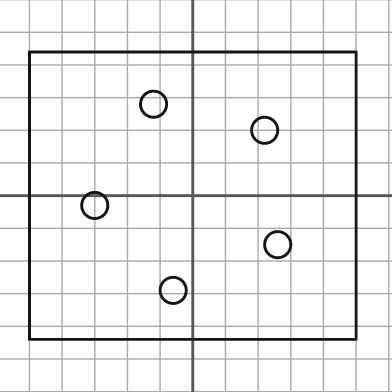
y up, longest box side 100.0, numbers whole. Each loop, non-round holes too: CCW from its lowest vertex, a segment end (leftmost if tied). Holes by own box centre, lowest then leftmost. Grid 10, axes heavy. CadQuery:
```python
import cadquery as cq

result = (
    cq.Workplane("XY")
    .moveTo(-50.0, -44.0)
    .lineTo(50.0, -44.0)
    .lineTo(50.0, 44.0)
    .lineTo(-50.0, 44.0)
    .close()
    .moveTo(-6.0, -29.0)
    .circle(4.0)
    .moveTo(26.0, -15.0)
    .circle(4.0)
    .moveTo(-30.0, -3.0)
    .circle(4.0)
    .moveTo(22.0, 20.0)
    .circle(4.0)
    .moveTo(-12.0, 28.0)
    .circle(4.0)
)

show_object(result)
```